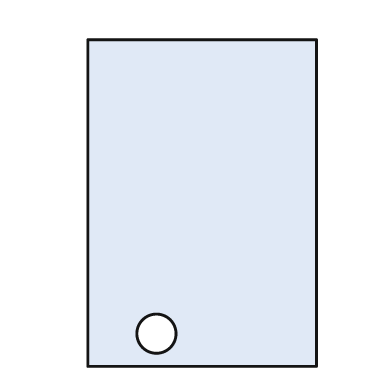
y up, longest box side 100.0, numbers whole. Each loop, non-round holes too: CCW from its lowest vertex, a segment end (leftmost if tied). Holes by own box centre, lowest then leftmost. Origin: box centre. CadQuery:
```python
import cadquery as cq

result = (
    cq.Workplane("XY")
    .moveTo(-35.0, -50.0)
    .lineTo(35.0, -50.0)
    .lineTo(35.0, 50.0)
    .lineTo(-35.0, 50.0)
    .close()
    .moveTo(-14.0, -40.0)
    .circle(6.0)
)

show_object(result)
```